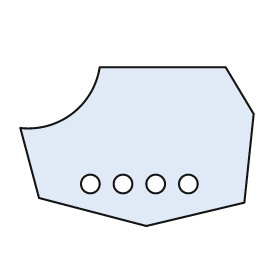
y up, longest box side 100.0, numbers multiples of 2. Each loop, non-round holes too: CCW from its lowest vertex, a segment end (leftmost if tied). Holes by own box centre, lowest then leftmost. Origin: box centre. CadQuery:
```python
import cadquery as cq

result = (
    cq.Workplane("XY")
    .moveTo(4.0, -34.0)
    .lineTo(46.0, -24.0)
    .lineTo(50.0, 14.0)
    .lineTo(38.0, 34.0)
    .lineTo(-16.0, 34.0)
    .threePointArc((-28.0, 14.0), (-50.0, 8.0))
    .lineTo(-42.0, -22.0)
    .close()
    .moveTo(-20.0, -16.0)
    .circle(4.0)
    .moveTo(-6.0, -16.0)
    .circle(4.0)
    .moveTo(8.0, -16.0)
    .circle(4.0)
    .moveTo(22.0, -16.0)
    .circle(4.0)
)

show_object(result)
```